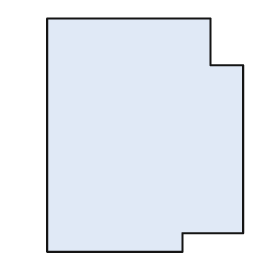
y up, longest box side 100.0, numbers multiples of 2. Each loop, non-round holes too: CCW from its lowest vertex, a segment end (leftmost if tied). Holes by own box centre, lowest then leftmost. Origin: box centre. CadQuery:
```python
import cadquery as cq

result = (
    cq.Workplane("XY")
    .moveTo(-42.0, -50.0)
    .lineTo(16.0, -50.0)
    .lineTo(16.0, -42.0)
    .lineTo(42.0, -42.0)
    .lineTo(42.0, 30.0)
    .lineTo(28.0, 30.0)
    .lineTo(28.0, 50.0)
    .lineTo(-42.0, 50.0)
    .close()
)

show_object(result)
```